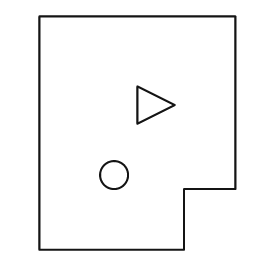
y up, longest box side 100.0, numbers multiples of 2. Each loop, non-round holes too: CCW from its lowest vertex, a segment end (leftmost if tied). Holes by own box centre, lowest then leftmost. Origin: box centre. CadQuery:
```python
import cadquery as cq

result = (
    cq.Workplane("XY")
    .moveTo(-42.0, -50.0)
    .lineTo(20.0, -50.0)
    .lineTo(20.0, -24.0)
    .lineTo(42.0, -24.0)
    .lineTo(42.0, 50.0)
    .lineTo(-42.0, 50.0)
    .close()
    .moveTo(-10.0, -18.0)
    .circle(6.0)
    .moveTo(0.0, 4.0)
    .lineTo(16.0, 12.0)
    .lineTo(0.0, 20.0)
    .close()
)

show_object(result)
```